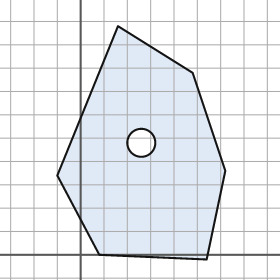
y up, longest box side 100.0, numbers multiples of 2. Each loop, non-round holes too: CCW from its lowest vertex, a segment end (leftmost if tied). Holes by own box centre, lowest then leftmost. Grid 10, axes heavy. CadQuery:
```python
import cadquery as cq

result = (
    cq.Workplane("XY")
    .moveTo(54.0, -2.0)
    .lineTo(62.0, 36.0)
    .lineTo(48.0, 78.0)
    .lineTo(16.0, 98.0)
    .lineTo(-10.0, 34.0)
    .lineTo(8.0, 0.0)
    .close()
    .moveTo(26.0, 48.0)
    .circle(6.0)
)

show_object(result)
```